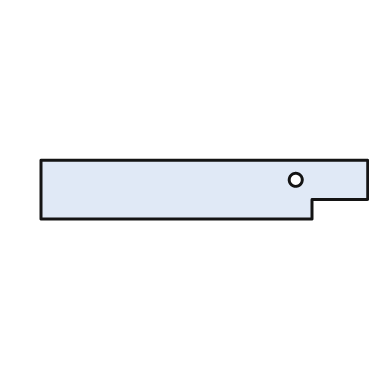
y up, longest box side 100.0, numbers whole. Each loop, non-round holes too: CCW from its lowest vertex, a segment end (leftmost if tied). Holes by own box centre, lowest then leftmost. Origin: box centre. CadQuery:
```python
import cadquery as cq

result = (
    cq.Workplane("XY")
    .moveTo(-50.0, -9.0)
    .lineTo(33.0, -9.0)
    .lineTo(33.0, -3.0)
    .lineTo(50.0, -3.0)
    .lineTo(50.0, 9.0)
    .lineTo(-50.0, 9.0)
    .close()
    .moveTo(28.0, 3.0)
    .circle(2.0)
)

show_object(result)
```